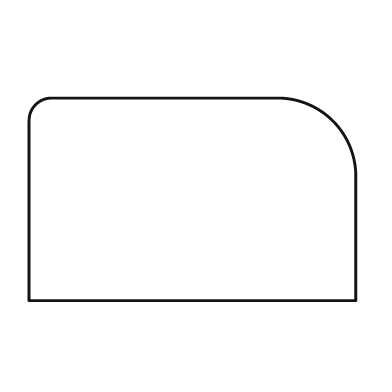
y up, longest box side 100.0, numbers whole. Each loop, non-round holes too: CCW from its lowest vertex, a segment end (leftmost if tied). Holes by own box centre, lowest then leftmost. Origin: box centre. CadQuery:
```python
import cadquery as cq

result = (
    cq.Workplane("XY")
    .moveTo(-50.0, -31.0)
    .lineTo(50.0, -31.0)
    .lineTo(50.0, 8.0)
    .threePointArc((43.0, 24.0), (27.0, 31.0))
    .lineTo(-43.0, 31.0)
    .threePointArc((-48.0, 29.0), (-50.0, 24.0))
    .close()
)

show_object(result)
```